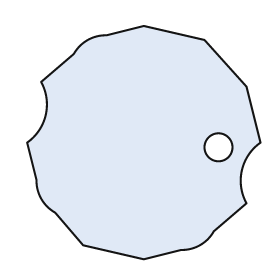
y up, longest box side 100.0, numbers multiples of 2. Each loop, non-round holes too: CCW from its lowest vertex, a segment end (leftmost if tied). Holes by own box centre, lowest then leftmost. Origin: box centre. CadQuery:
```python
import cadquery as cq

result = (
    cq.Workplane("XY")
    .moveTo(0.0, -50.0)
    .lineTo(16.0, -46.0)
    .threePointArc((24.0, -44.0), (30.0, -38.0))
    .lineTo(44.0, -26.0)
    .threePointArc((42.0, -12.0), (50.0, 0.0))
    .lineTo(44.0, 24.0)
    .lineTo(26.0, 44.0)
    .lineTo(0.0, 50.0)
    .lineTo(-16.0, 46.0)
    .threePointArc((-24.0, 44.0), (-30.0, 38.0))
    .lineTo(-44.0, 26.0)
    .threePointArc((-42.0, 12.0), (-50.0, 0.0))
    .lineTo(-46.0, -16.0)
    .threePointArc((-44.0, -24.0), (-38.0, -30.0))
    .lineTo(-26.0, -44.0)
    .close()
    .moveTo(32.0, -2.0)
    .circle(6.0)
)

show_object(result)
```